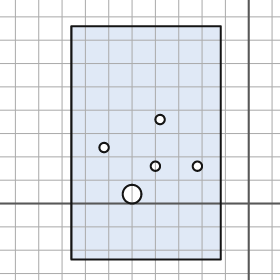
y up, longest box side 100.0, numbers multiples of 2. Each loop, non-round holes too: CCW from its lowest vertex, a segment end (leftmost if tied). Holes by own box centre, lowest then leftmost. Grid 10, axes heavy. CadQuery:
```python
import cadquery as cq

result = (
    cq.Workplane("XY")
    .moveTo(-76.0, -24.0)
    .lineTo(-12.0, -24.0)
    .lineTo(-12.0, 76.0)
    .lineTo(-76.0, 76.0)
    .close()
    .moveTo(-50.0, 4.0)
    .circle(4.0)
    .moveTo(-40.0, 16.0)
    .circle(2.0)
    .moveTo(-22.0, 16.0)
    .circle(2.0)
    .moveTo(-62.0, 24.0)
    .circle(2.0)
    .moveTo(-38.0, 36.0)
    .circle(2.0)
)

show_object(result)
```